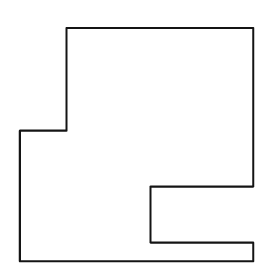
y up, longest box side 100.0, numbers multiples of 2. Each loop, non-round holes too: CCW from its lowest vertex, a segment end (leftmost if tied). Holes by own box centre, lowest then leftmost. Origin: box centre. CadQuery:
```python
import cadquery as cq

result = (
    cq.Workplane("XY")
    .moveTo(-50.0, -50.0)
    .lineTo(50.0, -50.0)
    .lineTo(50.0, -42.0)
    .lineTo(6.0, -42.0)
    .lineTo(6.0, -18.0)
    .lineTo(50.0, -18.0)
    .lineTo(50.0, 50.0)
    .lineTo(-30.0, 50.0)
    .lineTo(-30.0, 6.0)
    .lineTo(-50.0, 6.0)
    .close()
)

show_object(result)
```